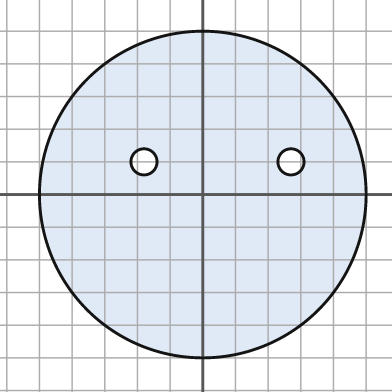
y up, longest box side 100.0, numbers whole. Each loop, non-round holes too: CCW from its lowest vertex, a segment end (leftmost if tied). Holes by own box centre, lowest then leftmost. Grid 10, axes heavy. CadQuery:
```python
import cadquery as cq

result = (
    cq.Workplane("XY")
    .moveTo(0.0, 0.0)
    .circle(50.0)
    .moveTo(-18.0, 10.0)
    .circle(4.0)
    .moveTo(27.0, 10.0)
    .circle(4.0)
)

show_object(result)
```